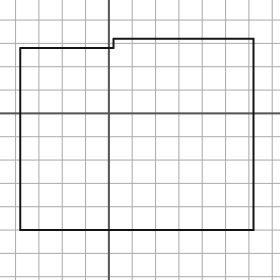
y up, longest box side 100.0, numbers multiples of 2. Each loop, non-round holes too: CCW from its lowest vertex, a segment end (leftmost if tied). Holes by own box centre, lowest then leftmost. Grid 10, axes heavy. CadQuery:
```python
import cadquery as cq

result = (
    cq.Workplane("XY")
    .moveTo(-38.0, -50.0)
    .lineTo(62.0, -50.0)
    .lineTo(62.0, 32.0)
    .lineTo(2.0, 32.0)
    .lineTo(2.0, 28.0)
    .lineTo(-38.0, 28.0)
    .close()
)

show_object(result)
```